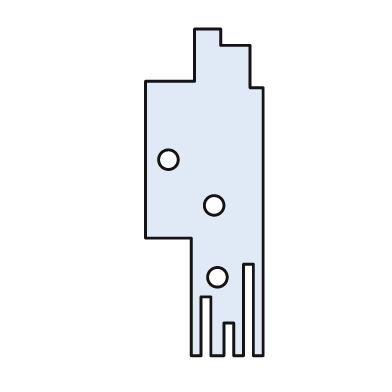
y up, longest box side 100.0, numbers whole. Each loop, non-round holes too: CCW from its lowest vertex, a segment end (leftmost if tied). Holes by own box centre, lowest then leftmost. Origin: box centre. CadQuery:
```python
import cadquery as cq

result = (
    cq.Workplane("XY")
    .moveTo(-4.0, -50.0)
    .lineTo(-1.0, -50.0)
    .lineTo(-1.0, -32.0)
    .lineTo(2.0, -32.0)
    .lineTo(2.0, -50.0)
    .lineTo(6.0, -50.0)
    .lineTo(6.0, -40.0)
    .lineTo(9.0, -40.0)
    .lineTo(9.0, -50.0)
    .lineTo(12.0, -50.0)
    .lineTo(12.0, -22.0)
    .lineTo(15.0, -22.0)
    .lineTo(15.0, -50.0)
    .lineTo(18.0, -50.0)
    .lineTo(18.0, 32.0)
    .lineTo(14.0, 32.0)
    .lineTo(14.0, 45.0)
    .lineTo(5.0, 45.0)
    .lineTo(5.0, 50.0)
    .lineTo(-3.0, 50.0)
    .lineTo(-3.0, 34.0)
    .lineTo(-18.0, 34.0)
    .lineTo(-18.0, -14.0)
    .lineTo(-4.0, -14.0)
    .close()
    .moveTo(4.0, -26.0)
    .circle(3.0)
    .moveTo(3.0, -4.0)
    .circle(3.0)
    .moveTo(-11.0, 10.0)
    .circle(3.0)
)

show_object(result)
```